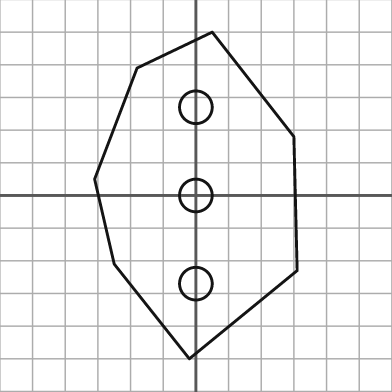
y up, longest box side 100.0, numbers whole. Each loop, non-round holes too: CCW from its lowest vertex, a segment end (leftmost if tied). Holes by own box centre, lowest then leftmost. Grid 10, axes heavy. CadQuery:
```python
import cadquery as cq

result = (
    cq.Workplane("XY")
    .moveTo(-2.0, -50.0)
    .lineTo(31.0, -23.0)
    .lineTo(30.0, 18.0)
    .lineTo(5.0, 50.0)
    .lineTo(-18.0, 39.0)
    .lineTo(-31.0, 5.0)
    .lineTo(-25.0, -21.0)
    .close()
    .moveTo(0.0, -27.0)
    .circle(5.0)
    .moveTo(0.0, 0.0)
    .circle(5.0)
    .moveTo(0.0, 27.0)
    .circle(5.0)
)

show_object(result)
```